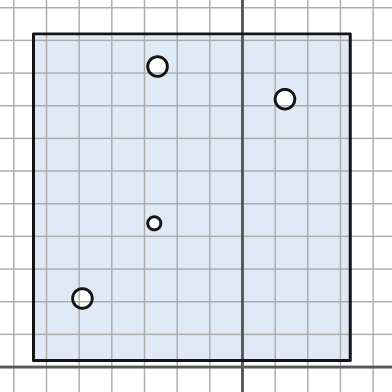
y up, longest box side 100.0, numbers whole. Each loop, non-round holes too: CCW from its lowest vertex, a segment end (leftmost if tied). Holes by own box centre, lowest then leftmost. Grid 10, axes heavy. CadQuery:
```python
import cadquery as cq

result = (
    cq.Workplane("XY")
    .moveTo(-64.0, 2.0)
    .lineTo(33.0, 2.0)
    .lineTo(33.0, 102.0)
    .lineTo(-64.0, 102.0)
    .close()
    .moveTo(-49.0, 21.0)
    .circle(3.0)
    .moveTo(-27.0, 44.0)
    .circle(2.0)
    .moveTo(13.0, 82.0)
    .circle(3.0)
    .moveTo(-26.0, 92.0)
    .circle(3.0)
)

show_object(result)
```